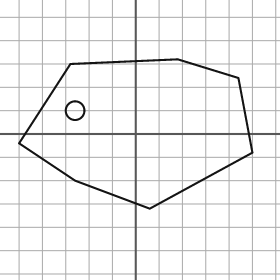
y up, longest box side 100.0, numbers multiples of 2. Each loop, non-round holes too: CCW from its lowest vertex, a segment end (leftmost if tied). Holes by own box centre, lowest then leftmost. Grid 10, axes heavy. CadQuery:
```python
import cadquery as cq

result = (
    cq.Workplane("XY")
    .moveTo(6.0, -32.0)
    .lineTo(50.0, -8.0)
    .lineTo(44.0, 24.0)
    .lineTo(18.0, 32.0)
    .lineTo(-28.0, 30.0)
    .lineTo(-50.0, -4.0)
    .lineTo(-26.0, -20.0)
    .close()
    .moveTo(-26.0, 10.0)
    .circle(4.0)
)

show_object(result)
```